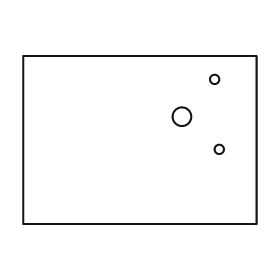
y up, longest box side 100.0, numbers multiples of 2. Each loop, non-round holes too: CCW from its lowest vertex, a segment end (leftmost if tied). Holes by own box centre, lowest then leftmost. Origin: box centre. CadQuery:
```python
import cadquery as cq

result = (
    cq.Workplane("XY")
    .moveTo(-50.0, -36.0)
    .lineTo(50.0, -36.0)
    .lineTo(50.0, 36.0)
    .lineTo(-50.0, 36.0)
    .close()
    .moveTo(34.0, -4.0)
    .circle(2.0)
    .moveTo(18.0, 10.0)
    .circle(4.0)
    .moveTo(32.0, 26.0)
    .circle(2.0)
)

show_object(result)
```